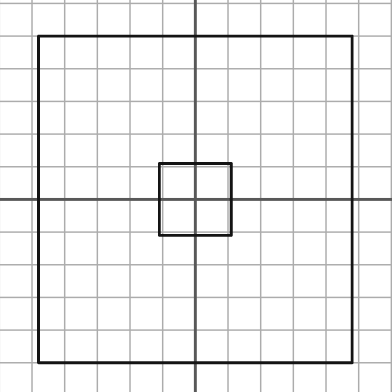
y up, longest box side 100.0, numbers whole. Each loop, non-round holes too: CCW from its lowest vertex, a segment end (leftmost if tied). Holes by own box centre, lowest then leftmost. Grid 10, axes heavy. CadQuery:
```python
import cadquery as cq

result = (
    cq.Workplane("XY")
    .moveTo(-48.0, -50.0)
    .lineTo(48.0, -50.0)
    .lineTo(48.0, 50.0)
    .lineTo(-48.0, 50.0)
    .close()
    .moveTo(-11.0, -11.0)
    .lineTo(11.0, -11.0)
    .lineTo(11.0, 11.0)
    .lineTo(-11.0, 11.0)
    .close()
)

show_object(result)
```